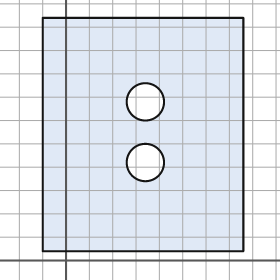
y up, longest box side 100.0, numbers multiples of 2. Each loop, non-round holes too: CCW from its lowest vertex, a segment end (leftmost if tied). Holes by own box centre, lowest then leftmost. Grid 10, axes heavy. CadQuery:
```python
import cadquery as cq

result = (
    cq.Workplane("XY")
    .moveTo(-10.0, 4.0)
    .lineTo(76.0, 4.0)
    .lineTo(76.0, 104.0)
    .lineTo(-10.0, 104.0)
    .close()
    .moveTo(34.0, 42.0)
    .circle(8.0)
    .moveTo(34.0, 68.0)
    .circle(8.0)
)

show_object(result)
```